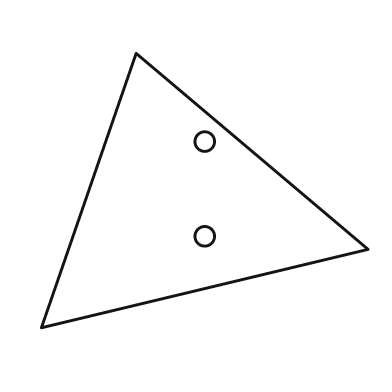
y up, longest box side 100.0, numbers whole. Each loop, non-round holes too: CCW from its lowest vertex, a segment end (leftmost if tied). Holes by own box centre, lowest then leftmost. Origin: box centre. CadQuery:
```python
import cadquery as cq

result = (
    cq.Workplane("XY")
    .moveTo(-50.0, -42.0)
    .lineTo(50.0, -18.0)
    .lineTo(-21.0, 42.0)
    .close()
    .moveTo(0.0, -14.0)
    .circle(3.0)
    .moveTo(0.0, 15.0)
    .circle(3.0)
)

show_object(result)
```